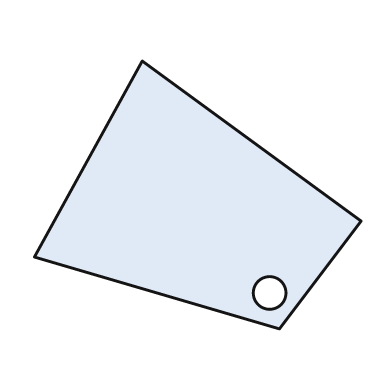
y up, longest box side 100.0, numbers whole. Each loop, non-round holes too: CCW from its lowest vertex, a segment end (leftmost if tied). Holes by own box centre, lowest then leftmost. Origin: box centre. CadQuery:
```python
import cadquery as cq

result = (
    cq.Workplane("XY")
    .moveTo(25.0, -41.0)
    .lineTo(50.0, -8.0)
    .lineTo(-17.0, 41.0)
    .lineTo(-50.0, -19.0)
    .close()
    .moveTo(22.0, -30.0)
    .circle(5.0)
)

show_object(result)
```